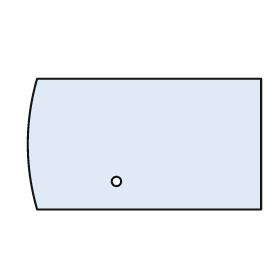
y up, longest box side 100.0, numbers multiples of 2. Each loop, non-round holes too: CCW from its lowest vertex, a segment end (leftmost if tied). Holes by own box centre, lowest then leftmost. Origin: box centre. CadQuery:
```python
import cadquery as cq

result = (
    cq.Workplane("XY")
    .moveTo(-46.0, -28.0)
    .lineTo(50.0, -28.0)
    .lineTo(50.0, 28.0)
    .lineTo(-46.0, 28.0)
    .threePointArc((-50.0, 0.0), (-46.0, -28.0))
    .close()
    .moveTo(-12.0, -16.0)
    .circle(2.0)
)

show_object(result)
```